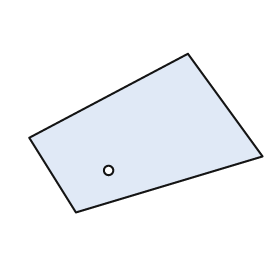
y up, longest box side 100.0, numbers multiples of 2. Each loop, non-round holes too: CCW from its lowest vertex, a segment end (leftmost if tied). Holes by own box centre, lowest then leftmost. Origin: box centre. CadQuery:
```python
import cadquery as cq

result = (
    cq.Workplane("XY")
    .moveTo(-30.0, -34.0)
    .lineTo(50.0, -10.0)
    .lineTo(18.0, 34.0)
    .lineTo(-50.0, -2.0)
    .close()
    .moveTo(-16.0, -16.0)
    .circle(2.0)
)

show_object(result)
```